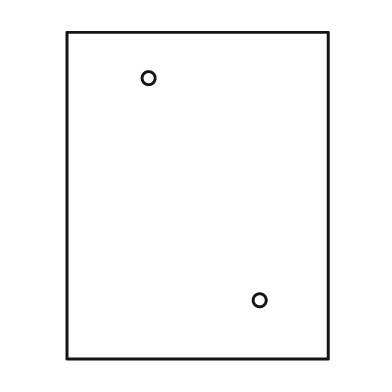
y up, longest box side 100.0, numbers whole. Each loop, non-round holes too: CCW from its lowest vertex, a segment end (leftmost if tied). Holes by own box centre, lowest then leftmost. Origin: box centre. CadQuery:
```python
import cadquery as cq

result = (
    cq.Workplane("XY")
    .moveTo(-40.0, -50.0)
    .lineTo(40.0, -50.0)
    .lineTo(40.0, 50.0)
    .lineTo(-40.0, 50.0)
    .close()
    .moveTo(19.0, -32.0)
    .circle(2.0)
    .moveTo(-15.0, 36.0)
    .circle(2.0)
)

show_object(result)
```